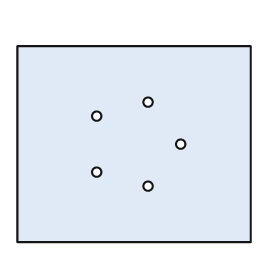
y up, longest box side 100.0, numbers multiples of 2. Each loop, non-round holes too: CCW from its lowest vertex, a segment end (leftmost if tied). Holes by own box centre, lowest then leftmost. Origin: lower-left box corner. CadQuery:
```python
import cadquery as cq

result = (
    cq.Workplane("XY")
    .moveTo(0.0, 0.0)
    .lineTo(100.0, 0.0)
    .lineTo(100.0, 84.0)
    .lineTo(0.0, 84.0)
    .close()
    .moveTo(56.0, 24.0)
    .circle(2.0)
    .moveTo(34.0, 30.0)
    .circle(2.0)
    .moveTo(70.0, 42.0)
    .circle(2.0)
    .moveTo(34.0, 54.0)
    .circle(2.0)
    .moveTo(56.0, 60.0)
    .circle(2.0)
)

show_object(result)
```